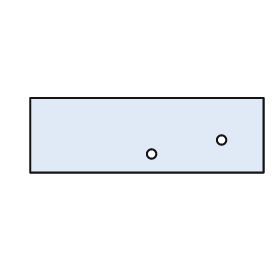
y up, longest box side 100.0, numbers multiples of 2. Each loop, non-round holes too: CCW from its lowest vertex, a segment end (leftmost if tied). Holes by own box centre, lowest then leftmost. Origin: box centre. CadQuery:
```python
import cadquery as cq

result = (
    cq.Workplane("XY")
    .moveTo(-50.0, -16.0)
    .lineTo(50.0, -16.0)
    .lineTo(50.0, 16.0)
    .lineTo(-50.0, 16.0)
    .close()
    .moveTo(2.0, -8.0)
    .circle(2.0)
    .moveTo(32.0, -2.0)
    .circle(2.0)
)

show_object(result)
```